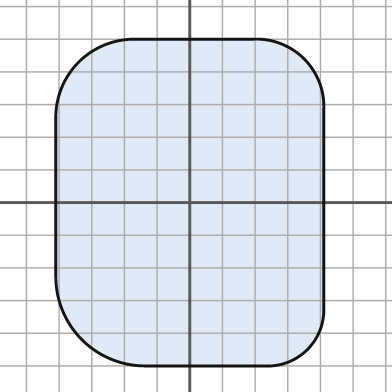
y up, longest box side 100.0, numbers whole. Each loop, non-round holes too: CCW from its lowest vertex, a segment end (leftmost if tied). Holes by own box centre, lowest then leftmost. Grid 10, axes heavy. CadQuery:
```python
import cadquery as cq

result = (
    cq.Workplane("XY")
    .moveTo(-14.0, -50.0)
    .lineTo(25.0, -50.0)
    .threePointArc((36.0, -45.0), (41.0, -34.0))
    .lineTo(41.0, 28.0)
    .threePointArc((35.0, 44.0), (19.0, 50.0))
    .lineTo(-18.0, 50.0)
    .threePointArc((-34.0, 43.0), (-41.0, 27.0))
    .lineTo(-41.0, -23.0)
    .threePointArc((-33.0, -42.0), (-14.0, -50.0))
    .close()
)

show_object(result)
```